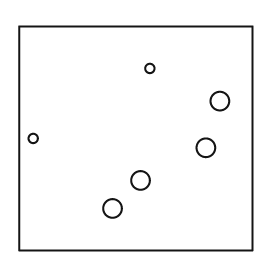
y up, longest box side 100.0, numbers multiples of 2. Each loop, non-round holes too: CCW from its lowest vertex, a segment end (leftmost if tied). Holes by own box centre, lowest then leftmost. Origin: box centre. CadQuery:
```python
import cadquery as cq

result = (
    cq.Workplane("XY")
    .moveTo(-50.0, -48.0)
    .lineTo(50.0, -48.0)
    .lineTo(50.0, 48.0)
    .lineTo(-50.0, 48.0)
    .close()
    .moveTo(-10.0, -30.0)
    .circle(4.0)
    .moveTo(2.0, -18.0)
    .circle(4.0)
    .moveTo(30.0, -4.0)
    .circle(4.0)
    .moveTo(-44.0, 0.0)
    .circle(2.0)
    .moveTo(36.0, 16.0)
    .circle(4.0)
    .moveTo(6.0, 30.0)
    .circle(2.0)
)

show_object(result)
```